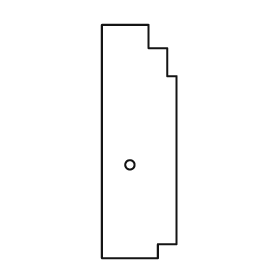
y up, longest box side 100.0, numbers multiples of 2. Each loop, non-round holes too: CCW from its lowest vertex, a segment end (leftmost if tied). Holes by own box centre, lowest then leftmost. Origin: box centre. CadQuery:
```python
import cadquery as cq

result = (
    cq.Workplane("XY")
    .moveTo(-16.0, -50.0)
    .lineTo(8.0, -50.0)
    .lineTo(8.0, -44.0)
    .lineTo(16.0, -44.0)
    .lineTo(16.0, 28.0)
    .lineTo(12.0, 28.0)
    .lineTo(12.0, 40.0)
    .lineTo(4.0, 40.0)
    .lineTo(4.0, 50.0)
    .lineTo(-16.0, 50.0)
    .close()
    .moveTo(-4.0, -10.0)
    .circle(2.0)
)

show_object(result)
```